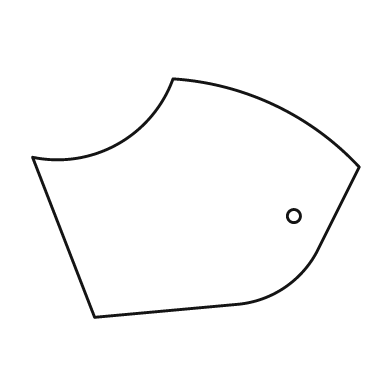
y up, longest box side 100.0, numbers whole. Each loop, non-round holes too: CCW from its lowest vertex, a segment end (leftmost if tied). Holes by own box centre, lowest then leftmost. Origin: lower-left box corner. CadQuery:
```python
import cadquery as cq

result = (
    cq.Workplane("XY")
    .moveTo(19.0, 0.0)
    .lineTo(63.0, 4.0)
    .threePointArc((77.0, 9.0), (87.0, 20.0))
    .lineTo(100.0, 46.0)
    .threePointArc((74.0, 65.0), (43.0, 73.0))
    .threePointArc((26.0, 53.0), (0.0, 49.0))
    .close()
    .moveTo(80.0, 31.0)
    .circle(2.0)
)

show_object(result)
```